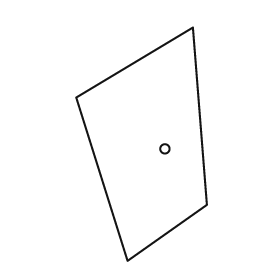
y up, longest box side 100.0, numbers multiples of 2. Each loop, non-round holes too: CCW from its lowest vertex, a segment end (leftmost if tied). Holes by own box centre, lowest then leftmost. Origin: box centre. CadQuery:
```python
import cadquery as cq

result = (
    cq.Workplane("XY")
    .moveTo(-6.0, -50.0)
    .lineTo(28.0, -26.0)
    .lineTo(22.0, 50.0)
    .lineTo(-28.0, 20.0)
    .close()
    .moveTo(10.0, -2.0)
    .circle(2.0)
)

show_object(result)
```